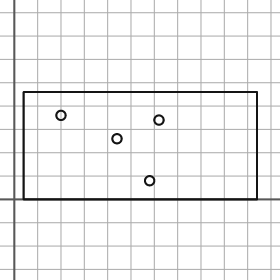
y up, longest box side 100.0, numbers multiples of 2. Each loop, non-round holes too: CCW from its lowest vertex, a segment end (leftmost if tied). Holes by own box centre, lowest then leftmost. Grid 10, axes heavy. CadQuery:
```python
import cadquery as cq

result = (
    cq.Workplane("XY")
    .moveTo(4.0, 0.0)
    .lineTo(104.0, 0.0)
    .lineTo(104.0, 46.0)
    .lineTo(4.0, 46.0)
    .close()
    .moveTo(58.0, 8.0)
    .circle(2.0)
    .moveTo(44.0, 26.0)
    .circle(2.0)
    .moveTo(62.0, 34.0)
    .circle(2.0)
    .moveTo(20.0, 36.0)
    .circle(2.0)
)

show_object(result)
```